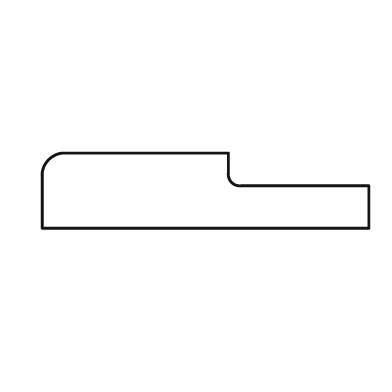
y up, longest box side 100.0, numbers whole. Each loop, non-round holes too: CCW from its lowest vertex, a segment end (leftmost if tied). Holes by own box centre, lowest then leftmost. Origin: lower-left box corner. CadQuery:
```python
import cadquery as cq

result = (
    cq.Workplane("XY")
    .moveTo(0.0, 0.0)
    .lineTo(100.0, 0.0)
    .lineTo(100.0, 13.0)
    .lineTo(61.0, 13.0)
    .threePointArc((58.0, 14.0), (57.0, 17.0))
    .lineTo(57.0, 23.0)
    .lineTo(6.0, 23.0)
    .threePointArc((2.0, 21.0), (0.0, 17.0))
    .close()
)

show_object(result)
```